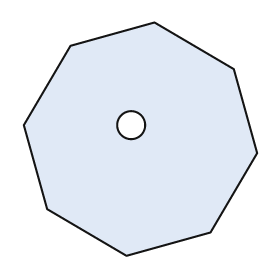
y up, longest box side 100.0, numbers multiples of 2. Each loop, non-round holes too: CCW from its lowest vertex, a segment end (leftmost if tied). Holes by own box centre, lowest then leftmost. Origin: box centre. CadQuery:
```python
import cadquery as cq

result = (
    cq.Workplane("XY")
    .moveTo(-6.0, -50.0)
    .lineTo(30.0, -40.0)
    .lineTo(50.0, -6.0)
    .lineTo(40.0, 30.0)
    .lineTo(6.0, 50.0)
    .lineTo(-30.0, 40.0)
    .lineTo(-50.0, 6.0)
    .lineTo(-40.0, -30.0)
    .close()
    .moveTo(-4.0, 6.0)
    .circle(6.0)
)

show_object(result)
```